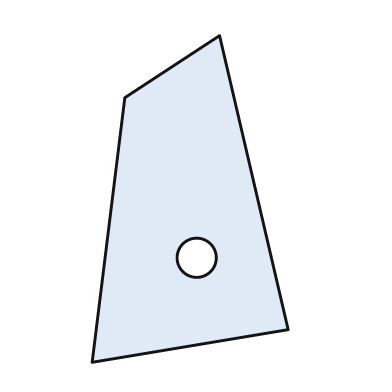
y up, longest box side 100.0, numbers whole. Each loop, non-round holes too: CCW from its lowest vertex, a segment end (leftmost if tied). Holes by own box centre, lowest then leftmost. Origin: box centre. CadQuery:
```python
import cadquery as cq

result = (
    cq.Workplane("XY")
    .moveTo(-30.0, -50.0)
    .lineTo(30.0, -40.0)
    .lineTo(9.0, 50.0)
    .lineTo(-20.0, 31.0)
    .close()
    .moveTo(2.0, -18.0)
    .circle(6.0)
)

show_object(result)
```